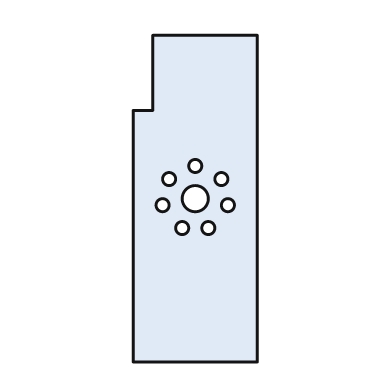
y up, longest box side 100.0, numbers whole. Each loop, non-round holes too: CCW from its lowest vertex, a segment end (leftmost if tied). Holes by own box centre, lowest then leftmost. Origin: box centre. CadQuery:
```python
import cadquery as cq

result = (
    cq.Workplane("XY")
    .moveTo(-19.0, -50.0)
    .lineTo(19.0, -50.0)
    .lineTo(19.0, 50.0)
    .lineTo(-13.0, 50.0)
    .lineTo(-13.0, 27.0)
    .lineTo(-19.0, 27.0)
    .close()
    .moveTo(-4.0, -9.0)
    .circle(2.0)
    .moveTo(4.0, -9.0)
    .circle(2.0)
    .moveTo(-10.0, -2.0)
    .circle(2.0)
    .moveTo(10.0, -2.0)
    .circle(2.0)
    .moveTo(0.0, 0.0)
    .circle(4.0)
    .moveTo(-8.0, 6.0)
    .circle(2.0)
    .moveTo(8.0, 6.0)
    .circle(2.0)
    .moveTo(0.0, 10.0)
    .circle(2.0)
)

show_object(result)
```